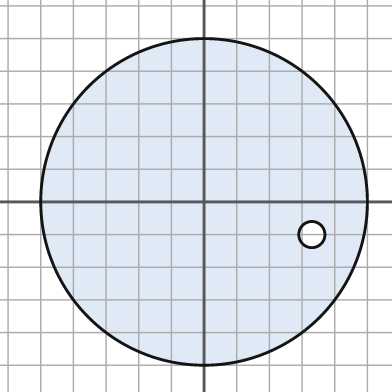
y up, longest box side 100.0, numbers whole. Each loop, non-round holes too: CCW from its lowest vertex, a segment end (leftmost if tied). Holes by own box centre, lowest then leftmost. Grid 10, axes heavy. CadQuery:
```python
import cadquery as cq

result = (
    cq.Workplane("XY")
    .moveTo(0.0, 0.0)
    .circle(50.0)
    .moveTo(33.0, -10.0)
    .circle(4.0)
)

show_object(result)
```